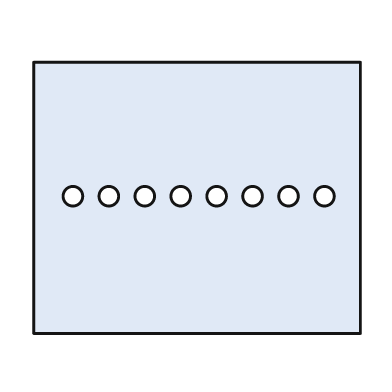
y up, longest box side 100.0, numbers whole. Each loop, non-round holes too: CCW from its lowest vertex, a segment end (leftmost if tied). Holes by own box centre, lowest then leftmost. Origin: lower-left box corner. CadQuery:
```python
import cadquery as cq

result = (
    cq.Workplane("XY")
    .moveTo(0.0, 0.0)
    .lineTo(100.0, 0.0)
    .lineTo(100.0, 83.0)
    .lineTo(0.0, 83.0)
    .close()
    .moveTo(12.0, 42.0)
    .circle(3.0)
    .moveTo(23.0, 42.0)
    .circle(3.0)
    .moveTo(34.0, 42.0)
    .circle(3.0)
    .moveTo(45.0, 42.0)
    .circle(3.0)
    .moveTo(56.0, 42.0)
    .circle(3.0)
    .moveTo(67.0, 42.0)
    .circle(3.0)
    .moveTo(78.0, 42.0)
    .circle(3.0)
    .moveTo(89.0, 42.0)
    .circle(3.0)
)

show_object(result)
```